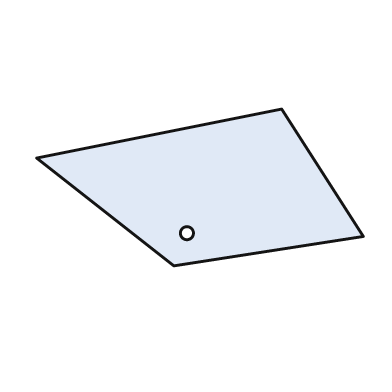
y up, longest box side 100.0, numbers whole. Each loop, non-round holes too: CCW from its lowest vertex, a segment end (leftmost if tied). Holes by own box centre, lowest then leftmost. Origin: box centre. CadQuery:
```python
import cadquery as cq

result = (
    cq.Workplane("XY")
    .moveTo(-8.0, -24.0)
    .lineTo(50.0, -15.0)
    .lineTo(25.0, 24.0)
    .lineTo(-50.0, 9.0)
    .close()
    .moveTo(-4.0, -14.0)
    .circle(2.0)
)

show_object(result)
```